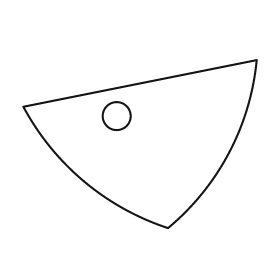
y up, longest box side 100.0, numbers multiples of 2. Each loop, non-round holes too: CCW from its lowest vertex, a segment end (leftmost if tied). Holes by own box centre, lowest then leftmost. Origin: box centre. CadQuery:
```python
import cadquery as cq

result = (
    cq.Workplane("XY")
    .moveTo(12.0, -36.0)
    .threePointArc((38.0, -4.0), (50.0, 36.0))
    .lineTo(-50.0, 16.0)
    .threePointArc((-24.0, -16.0), (12.0, -36.0))
    .close()
    .moveTo(-10.0, 12.0)
    .circle(6.0)
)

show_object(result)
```